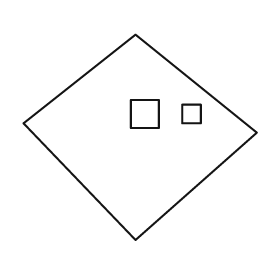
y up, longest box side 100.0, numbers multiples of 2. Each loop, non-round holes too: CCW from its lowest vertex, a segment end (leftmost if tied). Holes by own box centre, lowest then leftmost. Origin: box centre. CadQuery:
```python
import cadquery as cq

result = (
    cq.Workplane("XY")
    .moveTo(-2.0, -44.0)
    .lineTo(50.0, 2.0)
    .lineTo(-2.0, 44.0)
    .lineTo(-50.0, 6.0)
    .close()
    .moveTo(-4.0, 4.0)
    .lineTo(8.0, 4.0)
    .lineTo(8.0, 16.0)
    .lineTo(-4.0, 16.0)
    .close()
    .moveTo(18.0, 6.0)
    .lineTo(26.0, 6.0)
    .lineTo(26.0, 14.0)
    .lineTo(18.0, 14.0)
    .close()
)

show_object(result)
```